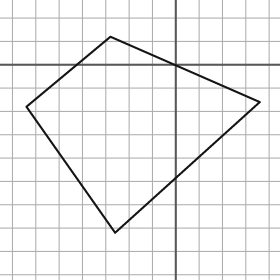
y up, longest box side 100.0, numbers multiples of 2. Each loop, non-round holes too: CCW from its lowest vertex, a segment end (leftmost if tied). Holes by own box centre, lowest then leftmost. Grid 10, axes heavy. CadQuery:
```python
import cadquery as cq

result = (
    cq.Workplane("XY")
    .moveTo(-26.0, -72.0)
    .lineTo(36.0, -16.0)
    .lineTo(-28.0, 12.0)
    .lineTo(-64.0, -18.0)
    .close()
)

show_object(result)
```